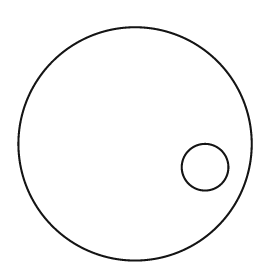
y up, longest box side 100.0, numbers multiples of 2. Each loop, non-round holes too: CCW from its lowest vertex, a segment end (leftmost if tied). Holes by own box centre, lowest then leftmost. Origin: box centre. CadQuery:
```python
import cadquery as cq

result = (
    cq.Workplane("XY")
    .moveTo(0.0, 0.0)
    .circle(50.0)
    .moveTo(30.0, -10.0)
    .circle(10.0)
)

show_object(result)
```